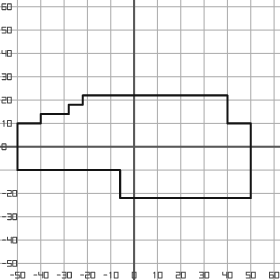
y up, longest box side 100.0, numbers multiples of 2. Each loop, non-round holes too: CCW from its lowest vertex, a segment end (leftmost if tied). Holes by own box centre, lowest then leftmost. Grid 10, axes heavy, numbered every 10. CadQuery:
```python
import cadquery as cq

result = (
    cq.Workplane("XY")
    .moveTo(-6.0, -22.0)
    .lineTo(50.0, -22.0)
    .lineTo(50.0, 10.0)
    .lineTo(40.0, 10.0)
    .lineTo(40.0, 22.0)
    .lineTo(-22.0, 22.0)
    .lineTo(-22.0, 18.0)
    .lineTo(-28.0, 18.0)
    .lineTo(-28.0, 14.0)
    .lineTo(-40.0, 14.0)
    .lineTo(-40.0, 10.0)
    .lineTo(-50.0, 10.0)
    .lineTo(-50.0, -10.0)
    .lineTo(-6.0, -10.0)
    .close()
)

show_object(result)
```